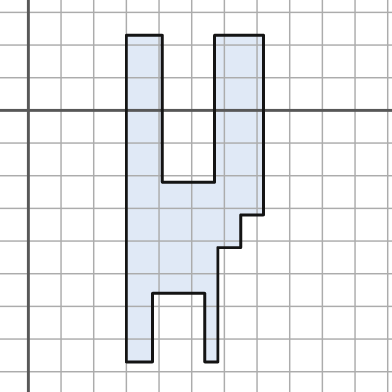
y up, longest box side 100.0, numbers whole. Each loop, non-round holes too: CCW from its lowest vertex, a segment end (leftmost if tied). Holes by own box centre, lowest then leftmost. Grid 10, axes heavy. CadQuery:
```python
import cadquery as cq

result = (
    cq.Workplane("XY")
    .moveTo(30.0, -77.0)
    .lineTo(38.0, -77.0)
    .lineTo(38.0, -56.0)
    .lineTo(54.0, -56.0)
    .lineTo(54.0, -77.0)
    .lineTo(58.0, -77.0)
    .lineTo(58.0, -42.0)
    .lineTo(65.0, -42.0)
    .lineTo(65.0, -32.0)
    .lineTo(72.0, -32.0)
    .lineTo(72.0, 23.0)
    .lineTo(57.0, 23.0)
    .lineTo(57.0, -22.0)
    .lineTo(41.0, -22.0)
    .lineTo(41.0, 23.0)
    .lineTo(30.0, 23.0)
    .close()
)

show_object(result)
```